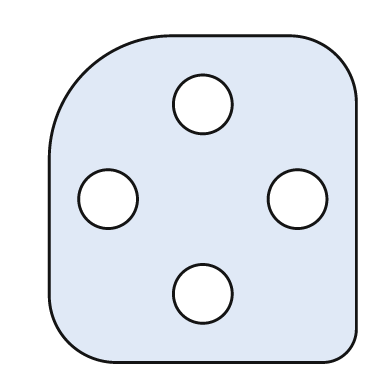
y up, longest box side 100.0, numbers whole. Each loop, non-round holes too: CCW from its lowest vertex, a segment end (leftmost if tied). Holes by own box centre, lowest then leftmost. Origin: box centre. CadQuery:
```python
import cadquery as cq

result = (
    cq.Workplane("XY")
    .moveTo(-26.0, -50.0)
    .lineTo(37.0, -50.0)
    .threePointArc((44.0, -47.0), (47.0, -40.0))
    .lineTo(47.0, 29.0)
    .threePointArc((41.0, 44.0), (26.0, 50.0))
    .lineTo(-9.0, 50.0)
    .threePointArc((-36.0, 39.0), (-47.0, 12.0))
    .lineTo(-47.0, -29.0)
    .threePointArc((-41.0, -44.0), (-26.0, -50.0))
    .close()
    .moveTo(0.0, -29.0)
    .circle(9.0)
    .moveTo(-29.0, 0.0)
    .circle(9.0)
    .moveTo(29.0, 0.0)
    .circle(9.0)
    .moveTo(0.0, 29.0)
    .circle(9.0)
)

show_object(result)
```